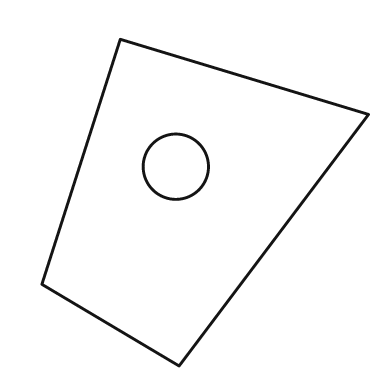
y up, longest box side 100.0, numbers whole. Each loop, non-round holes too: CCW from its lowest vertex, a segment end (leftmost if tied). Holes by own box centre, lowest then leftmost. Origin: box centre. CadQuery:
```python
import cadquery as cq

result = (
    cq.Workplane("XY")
    .moveTo(-8.0, -50.0)
    .lineTo(50.0, 27.0)
    .lineTo(-26.0, 50.0)
    .lineTo(-50.0, -25.0)
    .close()
    .moveTo(-9.0, 11.0)
    .circle(10.0)
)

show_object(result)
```